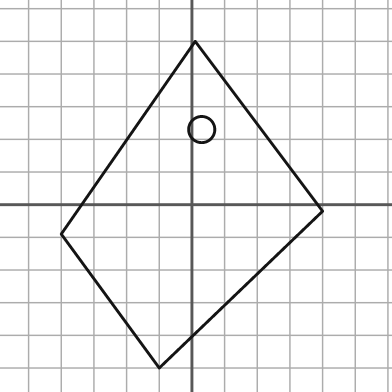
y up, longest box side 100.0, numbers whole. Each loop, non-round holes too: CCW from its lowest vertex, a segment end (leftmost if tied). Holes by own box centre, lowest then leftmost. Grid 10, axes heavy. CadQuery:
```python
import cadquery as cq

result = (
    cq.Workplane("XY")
    .moveTo(-10.0, -50.0)
    .lineTo(40.0, -2.0)
    .lineTo(1.0, 50.0)
    .lineTo(-40.0, -9.0)
    .close()
    .moveTo(3.0, 23.0)
    .circle(4.0)
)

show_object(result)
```